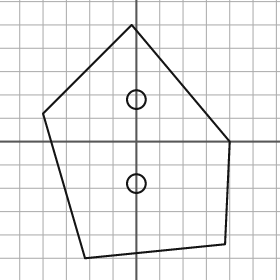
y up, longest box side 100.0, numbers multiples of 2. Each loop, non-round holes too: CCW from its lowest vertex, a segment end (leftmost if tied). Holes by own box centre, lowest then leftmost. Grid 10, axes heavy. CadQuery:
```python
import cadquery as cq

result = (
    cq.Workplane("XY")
    .moveTo(-22.0, -50.0)
    .lineTo(38.0, -44.0)
    .lineTo(40.0, 0.0)
    .lineTo(-2.0, 50.0)
    .lineTo(-40.0, 12.0)
    .close()
    .moveTo(0.0, -18.0)
    .circle(4.0)
    .moveTo(0.0, 18.0)
    .circle(4.0)
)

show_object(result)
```